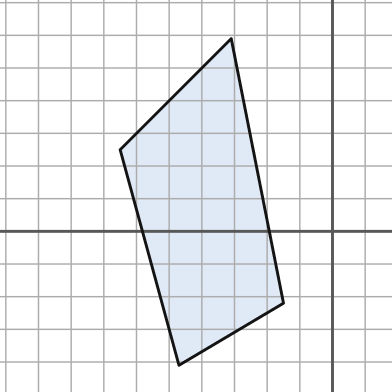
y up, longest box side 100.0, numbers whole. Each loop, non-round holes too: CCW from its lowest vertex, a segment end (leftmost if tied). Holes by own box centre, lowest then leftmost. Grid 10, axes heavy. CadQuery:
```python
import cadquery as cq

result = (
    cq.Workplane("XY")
    .moveTo(-47.0, -41.0)
    .lineTo(-15.0, -22.0)
    .lineTo(-31.0, 59.0)
    .lineTo(-65.0, 25.0)
    .close()
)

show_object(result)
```